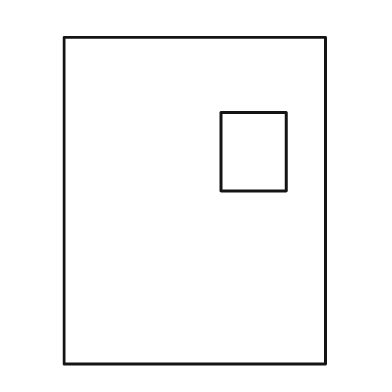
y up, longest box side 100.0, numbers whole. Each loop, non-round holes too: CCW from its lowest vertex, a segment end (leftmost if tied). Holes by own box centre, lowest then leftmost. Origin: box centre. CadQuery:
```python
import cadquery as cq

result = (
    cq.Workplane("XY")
    .moveTo(-40.0, -50.0)
    .lineTo(40.0, -50.0)
    .lineTo(40.0, 50.0)
    .lineTo(-40.0, 50.0)
    .close()
    .moveTo(8.0, 3.0)
    .lineTo(28.0, 3.0)
    .lineTo(28.0, 27.0)
    .lineTo(8.0, 27.0)
    .close()
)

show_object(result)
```